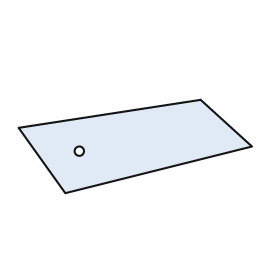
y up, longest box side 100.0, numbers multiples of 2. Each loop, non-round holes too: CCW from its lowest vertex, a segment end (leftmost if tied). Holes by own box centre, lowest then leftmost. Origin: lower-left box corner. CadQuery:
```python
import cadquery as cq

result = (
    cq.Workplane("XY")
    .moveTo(20.0, 0.0)
    .lineTo(100.0, 20.0)
    .lineTo(78.0, 40.0)
    .lineTo(0.0, 28.0)
    .close()
    .moveTo(26.0, 18.0)
    .circle(2.0)
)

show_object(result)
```